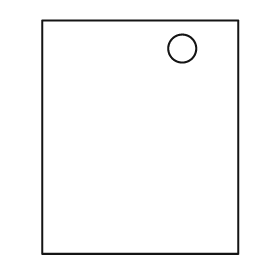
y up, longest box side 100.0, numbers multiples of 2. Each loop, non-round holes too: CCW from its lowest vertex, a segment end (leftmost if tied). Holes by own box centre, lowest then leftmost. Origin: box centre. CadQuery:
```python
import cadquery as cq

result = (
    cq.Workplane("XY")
    .moveTo(-42.0, -50.0)
    .lineTo(42.0, -50.0)
    .lineTo(42.0, 50.0)
    .lineTo(-42.0, 50.0)
    .close()
    .moveTo(18.0, 38.0)
    .circle(6.0)
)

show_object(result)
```